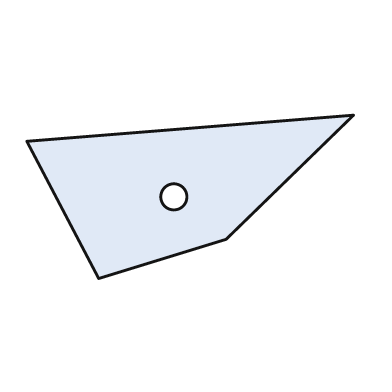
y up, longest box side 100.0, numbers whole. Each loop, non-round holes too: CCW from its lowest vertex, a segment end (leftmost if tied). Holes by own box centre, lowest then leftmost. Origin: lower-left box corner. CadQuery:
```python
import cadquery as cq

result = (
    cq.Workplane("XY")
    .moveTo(22.0, 0.0)
    .lineTo(61.0, 12.0)
    .lineTo(100.0, 50.0)
    .lineTo(0.0, 42.0)
    .close()
    .moveTo(45.0, 25.0)
    .circle(4.0)
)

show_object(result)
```